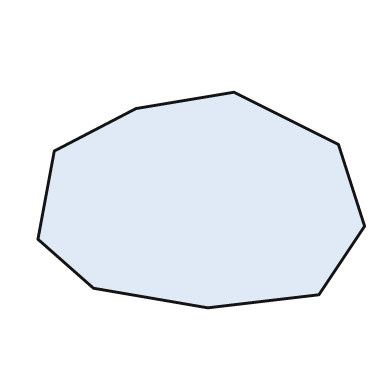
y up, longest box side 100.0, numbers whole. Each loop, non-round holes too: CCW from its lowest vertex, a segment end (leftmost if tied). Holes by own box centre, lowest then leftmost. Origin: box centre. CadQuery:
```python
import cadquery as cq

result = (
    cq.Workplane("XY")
    .moveTo(2.0, -33.0)
    .lineTo(36.0, -29.0)
    .lineTo(50.0, -8.0)
    .lineTo(42.0, 17.0)
    .lineTo(10.0, 33.0)
    .lineTo(-20.0, 28.0)
    .lineTo(-45.0, 15.0)
    .lineTo(-50.0, -12.0)
    .lineTo(-33.0, -27.0)
    .close()
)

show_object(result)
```